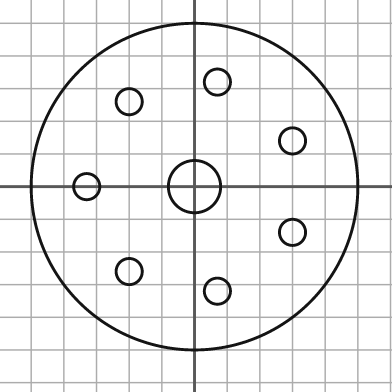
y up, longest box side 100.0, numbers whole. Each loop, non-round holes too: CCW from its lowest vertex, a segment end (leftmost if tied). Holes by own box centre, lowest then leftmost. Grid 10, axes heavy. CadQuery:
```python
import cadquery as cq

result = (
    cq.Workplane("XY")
    .moveTo(0.0, 0.0)
    .circle(50.0)
    .moveTo(7.0, -32.0)
    .circle(4.0)
    .moveTo(-20.0, -26.0)
    .circle(4.0)
    .moveTo(30.0, -14.0)
    .circle(4.0)
    .moveTo(-33.0, 0.0)
    .circle(4.0)
    .moveTo(0.0, 0.0)
    .circle(8.0)
    .moveTo(30.0, 14.0)
    .circle(4.0)
    .moveTo(-20.0, 26.0)
    .circle(4.0)
    .moveTo(7.0, 32.0)
    .circle(4.0)
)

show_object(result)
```